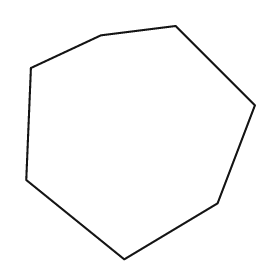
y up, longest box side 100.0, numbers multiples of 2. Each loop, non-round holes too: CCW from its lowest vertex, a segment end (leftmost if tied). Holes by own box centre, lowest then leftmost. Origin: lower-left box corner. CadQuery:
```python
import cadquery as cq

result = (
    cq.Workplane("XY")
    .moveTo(42.0, 0.0)
    .lineTo(82.0, 24.0)
    .lineTo(98.0, 66.0)
    .lineTo(64.0, 100.0)
    .lineTo(32.0, 96.0)
    .lineTo(2.0, 82.0)
    .lineTo(0.0, 34.0)
    .close()
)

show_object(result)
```